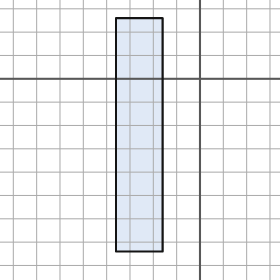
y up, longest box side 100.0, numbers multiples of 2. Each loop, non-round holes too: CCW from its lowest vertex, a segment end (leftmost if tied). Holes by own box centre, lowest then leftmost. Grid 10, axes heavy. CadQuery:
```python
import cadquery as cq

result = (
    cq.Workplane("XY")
    .moveTo(-36.0, -74.0)
    .lineTo(-16.0, -74.0)
    .lineTo(-16.0, 26.0)
    .lineTo(-36.0, 26.0)
    .close()
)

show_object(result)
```